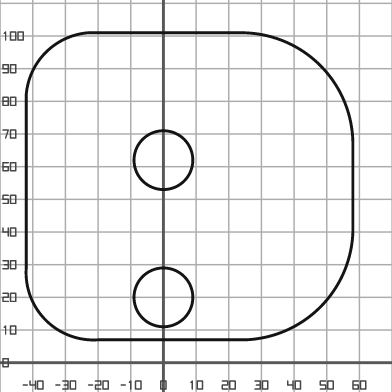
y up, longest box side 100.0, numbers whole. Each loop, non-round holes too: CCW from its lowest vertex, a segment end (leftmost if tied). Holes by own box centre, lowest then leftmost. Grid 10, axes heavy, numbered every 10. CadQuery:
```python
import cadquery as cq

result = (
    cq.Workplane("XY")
    .moveTo(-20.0, 7.0)
    .lineTo(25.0, 7.0)
    .threePointArc((48.0, 17.0), (58.0, 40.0))
    .lineTo(58.0, 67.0)
    .threePointArc((48.0, 91.0), (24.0, 101.0))
    .lineTo(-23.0, 101.0)
    .threePointArc((-36.0, 95.0), (-42.0, 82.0))
    .lineTo(-42.0, 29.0)
    .threePointArc((-36.0, 13.0), (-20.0, 7.0))
    .close()
    .moveTo(0.0, 20.0)
    .circle(9.0)
    .moveTo(0.0, 62.0)
    .circle(9.0)
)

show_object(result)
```